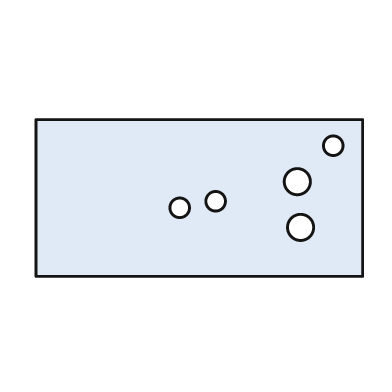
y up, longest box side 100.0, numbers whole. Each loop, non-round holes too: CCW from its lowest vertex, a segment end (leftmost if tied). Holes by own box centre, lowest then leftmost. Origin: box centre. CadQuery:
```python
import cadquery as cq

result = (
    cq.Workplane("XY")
    .moveTo(-50.0, -24.0)
    .lineTo(50.0, -24.0)
    .lineTo(50.0, 24.0)
    .lineTo(-50.0, 24.0)
    .close()
    .moveTo(31.0, -9.0)
    .circle(4.0)
    .moveTo(-6.0, -3.0)
    .circle(3.0)
    .moveTo(5.0, -1.0)
    .circle(3.0)
    .moveTo(30.0, 5.0)
    .circle(4.0)
    .moveTo(41.0, 16.0)
    .circle(3.0)
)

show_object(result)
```